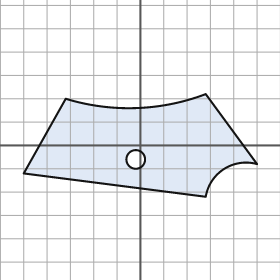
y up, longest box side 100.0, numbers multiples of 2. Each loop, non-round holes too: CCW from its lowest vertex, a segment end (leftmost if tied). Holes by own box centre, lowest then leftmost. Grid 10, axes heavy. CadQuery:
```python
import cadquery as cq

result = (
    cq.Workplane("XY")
    .moveTo(28.0, -22.0)
    .threePointArc((36.0, -10.0), (50.0, -8.0))
    .lineTo(28.0, 22.0)
    .threePointArc((-2.0, 16.0), (-32.0, 20.0))
    .lineTo(-50.0, -12.0)
    .close()
    .moveTo(-2.0, -6.0)
    .circle(4.0)
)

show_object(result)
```